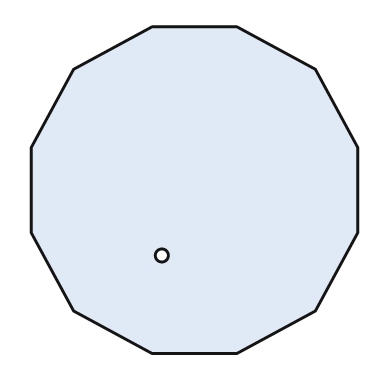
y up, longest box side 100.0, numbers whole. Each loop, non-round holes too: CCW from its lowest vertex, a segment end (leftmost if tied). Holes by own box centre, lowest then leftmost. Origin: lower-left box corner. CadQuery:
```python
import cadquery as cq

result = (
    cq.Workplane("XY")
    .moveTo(37.0, 0.0)
    .lineTo(63.0, 0.0)
    .lineTo(87.0, 13.0)
    .lineTo(100.0, 37.0)
    .lineTo(100.0, 63.0)
    .lineTo(87.0, 87.0)
    .lineTo(63.0, 100.0)
    .lineTo(37.0, 100.0)
    .lineTo(13.0, 87.0)
    .lineTo(0.0, 63.0)
    .lineTo(0.0, 37.0)
    .lineTo(13.0, 13.0)
    .close()
    .moveTo(40.0, 30.0)
    .circle(2.0)
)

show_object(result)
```